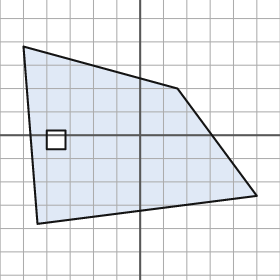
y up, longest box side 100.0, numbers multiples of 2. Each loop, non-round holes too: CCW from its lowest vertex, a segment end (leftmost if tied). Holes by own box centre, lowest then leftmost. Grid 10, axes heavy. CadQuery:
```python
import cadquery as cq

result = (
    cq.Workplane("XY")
    .moveTo(-44.0, -38.0)
    .lineTo(50.0, -26.0)
    .lineTo(16.0, 20.0)
    .lineTo(-50.0, 38.0)
    .close()
    .moveTo(-40.0, -6.0)
    .lineTo(-32.0, -6.0)
    .lineTo(-32.0, 2.0)
    .lineTo(-40.0, 2.0)
    .close()
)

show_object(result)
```